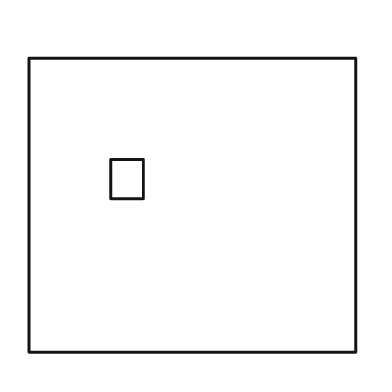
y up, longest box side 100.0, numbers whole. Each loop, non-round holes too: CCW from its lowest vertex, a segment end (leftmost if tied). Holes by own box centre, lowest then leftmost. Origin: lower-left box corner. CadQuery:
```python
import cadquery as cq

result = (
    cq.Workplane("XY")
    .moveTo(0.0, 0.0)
    .lineTo(100.0, 0.0)
    .lineTo(100.0, 90.0)
    .lineTo(0.0, 90.0)
    .close()
    .moveTo(25.0, 47.0)
    .lineTo(35.0, 47.0)
    .lineTo(35.0, 59.0)
    .lineTo(25.0, 59.0)
    .close()
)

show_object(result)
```